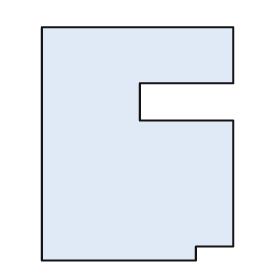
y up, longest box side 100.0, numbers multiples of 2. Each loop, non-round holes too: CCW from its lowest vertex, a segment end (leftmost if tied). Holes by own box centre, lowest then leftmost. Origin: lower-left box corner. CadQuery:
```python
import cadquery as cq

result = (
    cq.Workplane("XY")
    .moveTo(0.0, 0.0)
    .lineTo(66.0, 0.0)
    .lineTo(66.0, 6.0)
    .lineTo(82.0, 6.0)
    .lineTo(82.0, 60.0)
    .lineTo(42.0, 60.0)
    .lineTo(42.0, 76.0)
    .lineTo(82.0, 76.0)
    .lineTo(82.0, 100.0)
    .lineTo(0.0, 100.0)
    .close()
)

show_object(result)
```